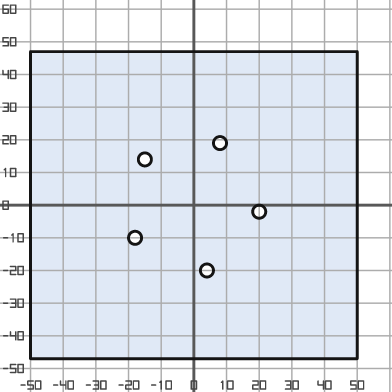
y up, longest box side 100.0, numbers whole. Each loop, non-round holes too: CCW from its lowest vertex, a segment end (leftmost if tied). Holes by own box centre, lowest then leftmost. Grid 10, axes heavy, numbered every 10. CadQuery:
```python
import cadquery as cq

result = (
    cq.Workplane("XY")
    .moveTo(-50.0, -47.0)
    .lineTo(50.0, -47.0)
    .lineTo(50.0, 47.0)
    .lineTo(-50.0, 47.0)
    .close()
    .moveTo(4.0, -20.0)
    .circle(2.0)
    .moveTo(-18.0, -10.0)
    .circle(2.0)
    .moveTo(20.0, -2.0)
    .circle(2.0)
    .moveTo(-15.0, 14.0)
    .circle(2.0)
    .moveTo(8.0, 19.0)
    .circle(2.0)
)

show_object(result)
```